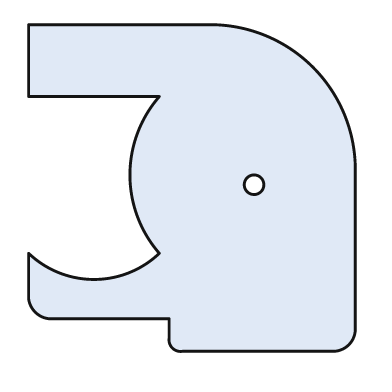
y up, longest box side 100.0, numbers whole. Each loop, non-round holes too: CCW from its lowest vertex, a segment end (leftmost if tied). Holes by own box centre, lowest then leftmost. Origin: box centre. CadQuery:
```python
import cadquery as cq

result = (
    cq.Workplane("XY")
    .moveTo(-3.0, -50.0)
    .lineTo(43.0, -50.0)
    .threePointArc((48.0, -48.0), (50.0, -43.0))
    .lineTo(50.0, 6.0)
    .threePointArc((37.0, 37.0), (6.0, 50.0))
    .lineTo(-50.0, 50.0)
    .lineTo(-50.0, 28.0)
    .lineTo(-10.0, 28.0)
    .threePointArc((-19.0, 4.0), (-10.0, -20.0))
    .threePointArc((-30.0, -28.0), (-50.0, -20.0))
    .lineTo(-50.0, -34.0)
    .threePointArc((-48.0, -38.0), (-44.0, -40.0))
    .lineTo(-7.0, -40.0)
    .lineTo(-7.0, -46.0)
    .threePointArc((-6.0, -49.0), (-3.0, -50.0))
    .close()
    .moveTo(19.0, 1.0)
    .circle(3.0)
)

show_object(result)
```